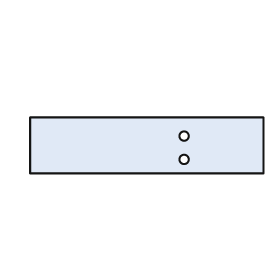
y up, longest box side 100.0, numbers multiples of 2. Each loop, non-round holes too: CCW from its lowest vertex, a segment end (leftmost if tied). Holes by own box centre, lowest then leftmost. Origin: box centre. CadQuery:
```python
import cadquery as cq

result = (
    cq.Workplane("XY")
    .moveTo(-50.0, -12.0)
    .lineTo(50.0, -12.0)
    .lineTo(50.0, 12.0)
    .lineTo(-50.0, 12.0)
    .close()
    .moveTo(16.0, -6.0)
    .circle(2.0)
    .moveTo(16.0, 4.0)
    .circle(2.0)
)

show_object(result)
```